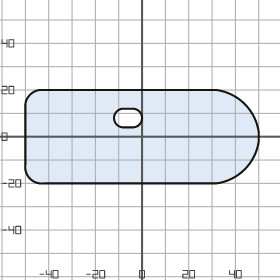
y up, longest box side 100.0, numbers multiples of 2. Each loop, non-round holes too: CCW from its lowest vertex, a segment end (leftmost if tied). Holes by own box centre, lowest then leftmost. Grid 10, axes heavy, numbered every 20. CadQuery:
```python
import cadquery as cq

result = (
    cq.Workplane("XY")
    .moveTo(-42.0, -20.0)
    .lineTo(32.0, -20.0)
    .threePointArc((44.0, -14.0), (50.0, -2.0))
    .lineTo(50.0, 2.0)
    .threePointArc((44.0, 14.0), (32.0, 20.0))
    .lineTo(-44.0, 20.0)
    .threePointArc((-48.0, 18.0), (-50.0, 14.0))
    .lineTo(-50.0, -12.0)
    .threePointArc((-48.0, -18.0), (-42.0, -20.0))
    .close()
    .moveTo(-8.0, 4.0)
    .lineTo(-4.0, 4.0)
    .threePointArc((0.0, 8.0), (-4.0, 12.0))
    .lineTo(-8.0, 12.0)
    .threePointArc((-12.0, 8.0), (-8.0, 4.0))
    .close()
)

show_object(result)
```